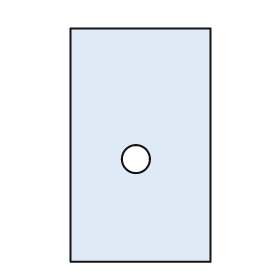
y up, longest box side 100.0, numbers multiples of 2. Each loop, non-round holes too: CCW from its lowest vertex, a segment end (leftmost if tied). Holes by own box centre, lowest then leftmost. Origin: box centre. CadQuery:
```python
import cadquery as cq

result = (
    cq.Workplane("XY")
    .moveTo(-30.0, -50.0)
    .lineTo(30.0, -50.0)
    .lineTo(30.0, 50.0)
    .lineTo(-30.0, 50.0)
    .close()
    .moveTo(-2.0, -6.0)
    .circle(6.0)
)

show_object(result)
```